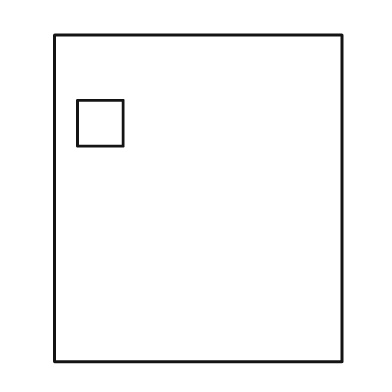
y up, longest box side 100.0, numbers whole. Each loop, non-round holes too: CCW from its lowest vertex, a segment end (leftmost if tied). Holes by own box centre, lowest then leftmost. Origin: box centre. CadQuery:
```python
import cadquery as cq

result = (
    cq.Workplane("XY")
    .moveTo(-44.0, -50.0)
    .lineTo(44.0, -50.0)
    .lineTo(44.0, 50.0)
    .lineTo(-44.0, 50.0)
    .close()
    .moveTo(-37.0, 16.0)
    .lineTo(-23.0, 16.0)
    .lineTo(-23.0, 30.0)
    .lineTo(-37.0, 30.0)
    .close()
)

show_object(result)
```